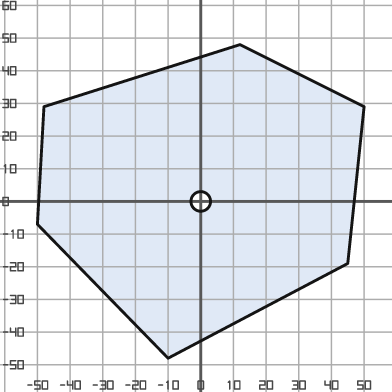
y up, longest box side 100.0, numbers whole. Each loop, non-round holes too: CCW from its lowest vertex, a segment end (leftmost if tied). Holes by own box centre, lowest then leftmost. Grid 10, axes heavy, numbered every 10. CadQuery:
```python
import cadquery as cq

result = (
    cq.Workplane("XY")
    .moveTo(-10.0, -48.0)
    .lineTo(45.0, -19.0)
    .lineTo(50.0, 29.0)
    .lineTo(12.0, 48.0)
    .lineTo(-48.0, 29.0)
    .lineTo(-50.0, -7.0)
    .close()
    .moveTo(0.0, 0.0)
    .circle(3.0)
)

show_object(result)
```